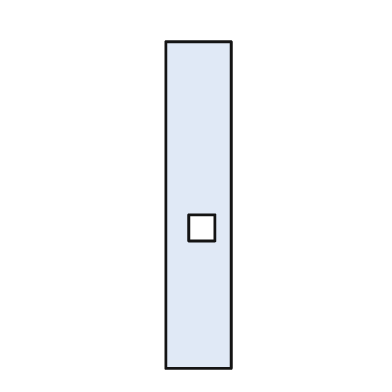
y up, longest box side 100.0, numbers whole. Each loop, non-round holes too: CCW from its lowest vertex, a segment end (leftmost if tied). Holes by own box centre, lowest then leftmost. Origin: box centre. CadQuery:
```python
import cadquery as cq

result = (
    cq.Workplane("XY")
    .moveTo(-10.0, -50.0)
    .lineTo(10.0, -50.0)
    .lineTo(10.0, 50.0)
    .lineTo(-10.0, 50.0)
    .close()
    .moveTo(-3.0, -11.0)
    .lineTo(5.0, -11.0)
    .lineTo(5.0, -3.0)
    .lineTo(-3.0, -3.0)
    .close()
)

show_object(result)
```